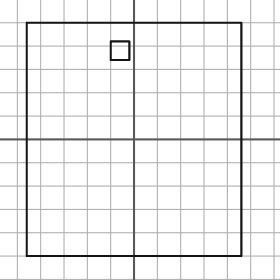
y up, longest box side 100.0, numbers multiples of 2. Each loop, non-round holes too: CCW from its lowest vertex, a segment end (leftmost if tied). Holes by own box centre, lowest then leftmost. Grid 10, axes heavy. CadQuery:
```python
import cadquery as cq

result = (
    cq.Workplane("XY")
    .moveTo(-46.0, -50.0)
    .lineTo(46.0, -50.0)
    .lineTo(46.0, 50.0)
    .lineTo(-46.0, 50.0)
    .close()
    .moveTo(-10.0, 34.0)
    .lineTo(-2.0, 34.0)
    .lineTo(-2.0, 42.0)
    .lineTo(-10.0, 42.0)
    .close()
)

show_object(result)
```